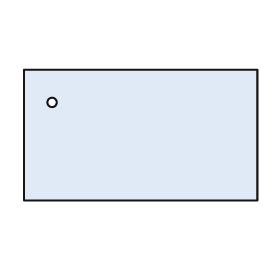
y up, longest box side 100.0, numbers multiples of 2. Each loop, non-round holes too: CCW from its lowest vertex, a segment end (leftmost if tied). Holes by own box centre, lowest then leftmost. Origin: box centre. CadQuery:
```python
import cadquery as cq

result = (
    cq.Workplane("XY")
    .moveTo(-50.0, -28.0)
    .lineTo(50.0, -28.0)
    .lineTo(50.0, 28.0)
    .lineTo(-50.0, 28.0)
    .close()
    .moveTo(-38.0, 14.0)
    .circle(2.0)
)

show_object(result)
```